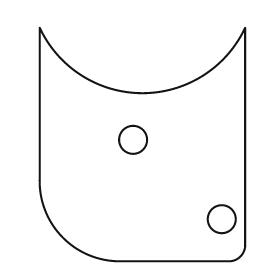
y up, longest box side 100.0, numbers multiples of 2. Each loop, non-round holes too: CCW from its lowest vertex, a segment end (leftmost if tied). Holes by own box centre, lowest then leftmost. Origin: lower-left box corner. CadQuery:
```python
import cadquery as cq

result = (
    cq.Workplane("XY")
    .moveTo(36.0, 0.0)
    .lineTo(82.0, 0.0)
    .threePointArc((86.0, 2.0), (88.0, 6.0))
    .lineTo(88.0, 100.0)
    .threePointArc((44.0, 72.0), (0.0, 100.0))
    .lineTo(0.0, 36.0)
    .threePointArc((10.0, 10.0), (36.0, 0.0))
    .close()
    .moveTo(78.0, 18.0)
    .circle(6.0)
    .moveTo(40.0, 52.0)
    .circle(6.0)
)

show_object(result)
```